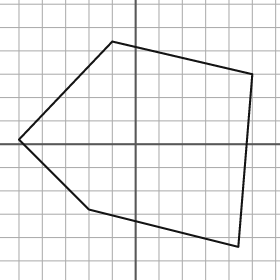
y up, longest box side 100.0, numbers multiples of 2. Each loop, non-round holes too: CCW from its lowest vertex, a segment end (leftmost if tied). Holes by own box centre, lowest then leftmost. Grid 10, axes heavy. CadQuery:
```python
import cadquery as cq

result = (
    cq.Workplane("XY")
    .moveTo(44.0, -44.0)
    .lineTo(50.0, 30.0)
    .lineTo(-10.0, 44.0)
    .lineTo(-50.0, 2.0)
    .lineTo(-20.0, -28.0)
    .close()
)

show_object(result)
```